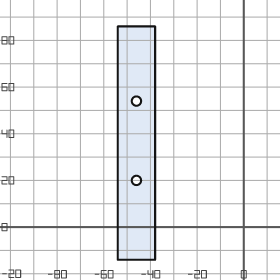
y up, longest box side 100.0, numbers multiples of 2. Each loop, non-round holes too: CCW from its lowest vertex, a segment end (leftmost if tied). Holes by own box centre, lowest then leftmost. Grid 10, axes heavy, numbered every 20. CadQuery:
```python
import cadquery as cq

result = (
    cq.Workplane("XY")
    .moveTo(-54.0, -14.0)
    .lineTo(-38.0, -14.0)
    .lineTo(-38.0, 86.0)
    .lineTo(-54.0, 86.0)
    .close()
    .moveTo(-46.0, 20.0)
    .circle(2.0)
    .moveTo(-46.0, 54.0)
    .circle(2.0)
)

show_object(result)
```